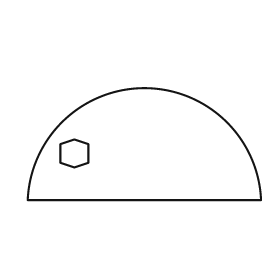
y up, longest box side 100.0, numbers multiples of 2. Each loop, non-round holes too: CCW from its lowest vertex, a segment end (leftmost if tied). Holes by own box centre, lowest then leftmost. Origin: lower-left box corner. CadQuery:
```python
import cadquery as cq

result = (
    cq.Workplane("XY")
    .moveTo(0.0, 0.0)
    .lineTo(100.0, 0.0)
    .threePointArc((50.0, 48.0), (0.0, 0.0))
    .close()
    .moveTo(20.0, 14.0)
    .lineTo(26.0, 16.0)
    .lineTo(26.0, 24.0)
    .lineTo(20.0, 26.0)
    .lineTo(14.0, 24.0)
    .lineTo(14.0, 16.0)
    .close()
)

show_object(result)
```